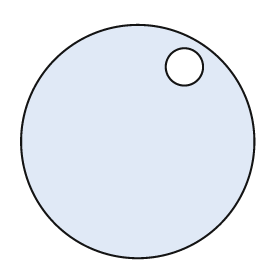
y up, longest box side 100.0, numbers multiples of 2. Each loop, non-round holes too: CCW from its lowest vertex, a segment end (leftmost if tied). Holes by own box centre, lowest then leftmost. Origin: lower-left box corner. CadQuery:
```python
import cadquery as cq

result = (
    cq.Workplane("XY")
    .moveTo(50.0, 50.0)
    .circle(50.0)
    .moveTo(70.0, 82.0)
    .circle(8.0)
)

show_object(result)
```